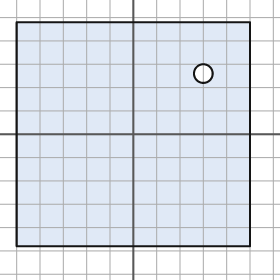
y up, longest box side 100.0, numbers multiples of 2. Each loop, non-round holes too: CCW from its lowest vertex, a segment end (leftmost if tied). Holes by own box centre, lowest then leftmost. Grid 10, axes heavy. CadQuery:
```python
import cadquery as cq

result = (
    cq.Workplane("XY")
    .moveTo(-50.0, -48.0)
    .lineTo(50.0, -48.0)
    .lineTo(50.0, 48.0)
    .lineTo(-50.0, 48.0)
    .close()
    .moveTo(30.0, 26.0)
    .circle(4.0)
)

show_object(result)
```